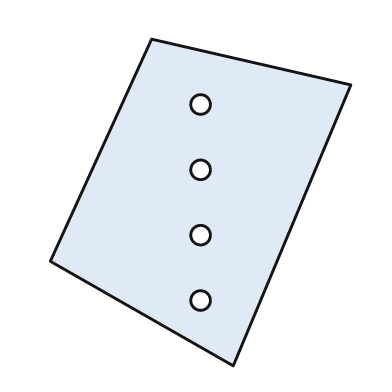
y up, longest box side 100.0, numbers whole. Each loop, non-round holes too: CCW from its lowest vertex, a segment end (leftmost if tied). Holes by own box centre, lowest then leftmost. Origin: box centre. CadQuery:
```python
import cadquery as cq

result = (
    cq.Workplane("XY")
    .moveTo(10.0, -50.0)
    .lineTo(46.0, 36.0)
    .lineTo(-15.0, 50.0)
    .lineTo(-46.0, -18.0)
    .close()
    .moveTo(0.0, -30.0)
    .circle(3.0)
    .moveTo(0.0, -10.0)
    .circle(3.0)
    .moveTo(0.0, 10.0)
    .circle(3.0)
    .moveTo(0.0, 30.0)
    .circle(3.0)
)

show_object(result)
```